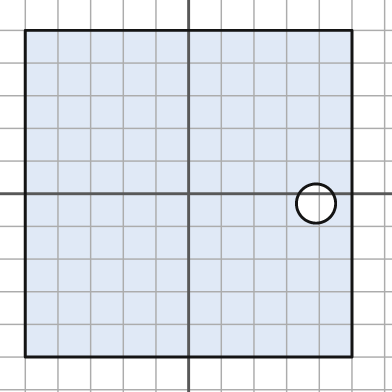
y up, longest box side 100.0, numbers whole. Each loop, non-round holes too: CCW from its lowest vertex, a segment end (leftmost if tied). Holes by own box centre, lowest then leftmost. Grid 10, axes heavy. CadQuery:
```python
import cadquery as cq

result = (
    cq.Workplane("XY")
    .moveTo(-50.0, -50.0)
    .lineTo(50.0, -50.0)
    .lineTo(50.0, 50.0)
    .lineTo(-50.0, 50.0)
    .close()
    .moveTo(39.0, -3.0)
    .circle(6.0)
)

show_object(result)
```